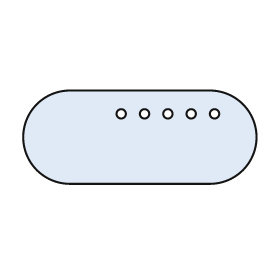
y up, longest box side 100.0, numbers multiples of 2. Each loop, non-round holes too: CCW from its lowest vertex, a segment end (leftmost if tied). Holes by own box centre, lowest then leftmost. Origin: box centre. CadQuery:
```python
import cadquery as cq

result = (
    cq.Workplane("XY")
    .moveTo(-30.0, -20.0)
    .lineTo(30.0, -20.0)
    .threePointArc((50.0, 0.0), (30.0, 20.0))
    .lineTo(-30.0, 20.0)
    .threePointArc((-50.0, 0.0), (-30.0, -20.0))
    .close()
    .moveTo(-8.0, 10.0)
    .circle(2.0)
    .moveTo(2.0, 10.0)
    .circle(2.0)
    .moveTo(12.0, 10.0)
    .circle(2.0)
    .moveTo(22.0, 10.0)
    .circle(2.0)
    .moveTo(32.0, 10.0)
    .circle(2.0)
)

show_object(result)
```